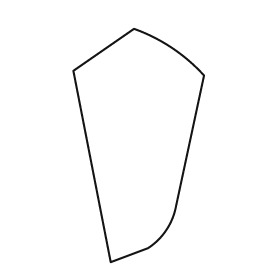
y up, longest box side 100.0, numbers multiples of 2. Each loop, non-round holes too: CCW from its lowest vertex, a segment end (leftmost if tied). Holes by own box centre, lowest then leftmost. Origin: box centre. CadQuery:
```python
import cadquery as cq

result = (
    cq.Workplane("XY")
    .moveTo(-12.0, -50.0)
    .lineTo(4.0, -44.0)
    .threePointArc((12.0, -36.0), (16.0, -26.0))
    .lineTo(28.0, 30.0)
    .threePointArc((14.0, 42.0), (-2.0, 50.0))
    .lineTo(-28.0, 32.0)
    .close()
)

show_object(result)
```